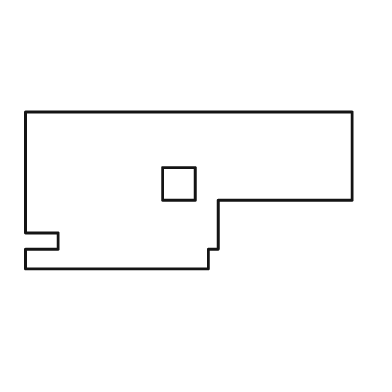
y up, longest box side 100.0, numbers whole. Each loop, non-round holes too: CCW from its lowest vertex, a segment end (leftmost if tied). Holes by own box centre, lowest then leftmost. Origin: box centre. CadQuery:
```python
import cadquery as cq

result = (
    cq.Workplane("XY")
    .moveTo(-50.0, -24.0)
    .lineTo(6.0, -24.0)
    .lineTo(6.0, -18.0)
    .lineTo(9.0, -18.0)
    .lineTo(9.0, -3.0)
    .lineTo(50.0, -3.0)
    .lineTo(50.0, 24.0)
    .lineTo(-50.0, 24.0)
    .lineTo(-50.0, -13.0)
    .lineTo(-40.0, -13.0)
    .lineTo(-40.0, -18.0)
    .lineTo(-50.0, -18.0)
    .close()
    .moveTo(-8.0, -3.0)
    .lineTo(2.0, -3.0)
    .lineTo(2.0, 7.0)
    .lineTo(-8.0, 7.0)
    .close()
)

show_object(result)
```